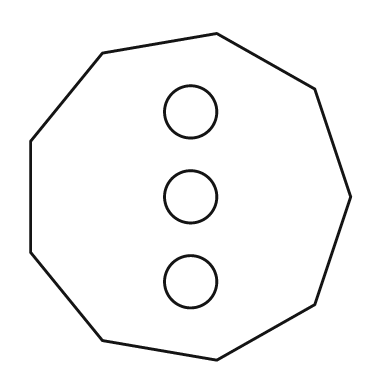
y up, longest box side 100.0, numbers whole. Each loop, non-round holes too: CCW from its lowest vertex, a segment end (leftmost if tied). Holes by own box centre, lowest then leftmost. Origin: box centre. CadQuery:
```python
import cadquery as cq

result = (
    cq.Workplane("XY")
    .moveTo(8.0, -50.0)
    .lineTo(38.0, -33.0)
    .lineTo(49.0, 0.0)
    .lineTo(38.0, 33.0)
    .lineTo(8.0, 50.0)
    .lineTo(-27.0, 44.0)
    .lineTo(-49.0, 17.0)
    .lineTo(-49.0, -17.0)
    .lineTo(-27.0, -44.0)
    .close()
    .moveTo(0.0, -26.0)
    .circle(8.0)
    .moveTo(0.0, 0.0)
    .circle(8.0)
    .moveTo(0.0, 26.0)
    .circle(8.0)
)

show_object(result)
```